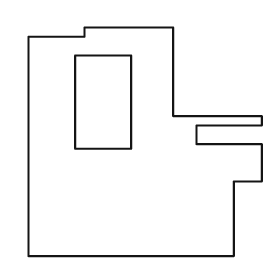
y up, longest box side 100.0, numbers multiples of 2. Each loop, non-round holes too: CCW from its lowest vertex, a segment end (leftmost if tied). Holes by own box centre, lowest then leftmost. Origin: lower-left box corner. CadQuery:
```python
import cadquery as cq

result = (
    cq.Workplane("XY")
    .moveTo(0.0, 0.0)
    .lineTo(88.0, 0.0)
    .lineTo(88.0, 32.0)
    .lineTo(100.0, 32.0)
    .lineTo(100.0, 48.0)
    .lineTo(72.0, 48.0)
    .lineTo(72.0, 56.0)
    .lineTo(100.0, 56.0)
    .lineTo(100.0, 60.0)
    .lineTo(62.0, 60.0)
    .lineTo(62.0, 98.0)
    .lineTo(24.0, 98.0)
    .lineTo(24.0, 94.0)
    .lineTo(0.0, 94.0)
    .close()
    .moveTo(20.0, 46.0)
    .lineTo(44.0, 46.0)
    .lineTo(44.0, 86.0)
    .lineTo(20.0, 86.0)
    .close()
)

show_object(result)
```